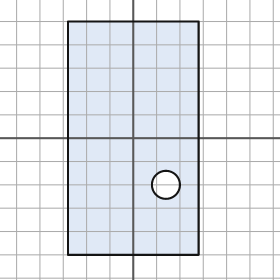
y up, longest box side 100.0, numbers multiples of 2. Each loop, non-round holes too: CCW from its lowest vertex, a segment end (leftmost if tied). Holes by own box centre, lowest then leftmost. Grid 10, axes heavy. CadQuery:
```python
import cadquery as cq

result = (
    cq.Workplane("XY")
    .moveTo(-28.0, -50.0)
    .lineTo(28.0, -50.0)
    .lineTo(28.0, 50.0)
    .lineTo(-28.0, 50.0)
    .close()
    .moveTo(14.0, -20.0)
    .circle(6.0)
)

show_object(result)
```